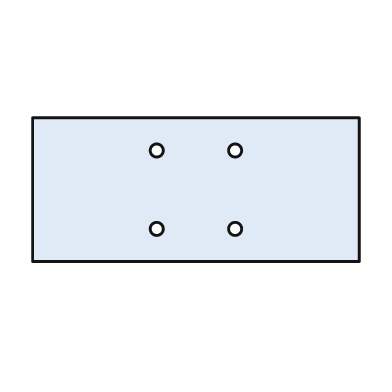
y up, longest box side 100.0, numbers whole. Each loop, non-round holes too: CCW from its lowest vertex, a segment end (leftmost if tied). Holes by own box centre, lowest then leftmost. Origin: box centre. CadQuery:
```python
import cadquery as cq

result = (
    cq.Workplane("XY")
    .moveTo(-50.0, -22.0)
    .lineTo(50.0, -22.0)
    .lineTo(50.0, 22.0)
    .lineTo(-50.0, 22.0)
    .close()
    .moveTo(-12.0, -12.0)
    .circle(2.0)
    .moveTo(12.0, -12.0)
    .circle(2.0)
    .moveTo(-12.0, 12.0)
    .circle(2.0)
    .moveTo(12.0, 12.0)
    .circle(2.0)
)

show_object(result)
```